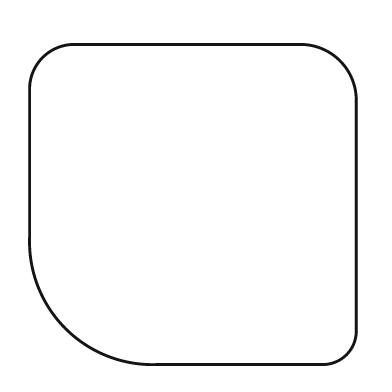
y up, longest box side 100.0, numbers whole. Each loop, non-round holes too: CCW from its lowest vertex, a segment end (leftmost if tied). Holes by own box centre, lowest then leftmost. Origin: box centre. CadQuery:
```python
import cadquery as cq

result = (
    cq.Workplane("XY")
    .moveTo(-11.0, -49.0)
    .lineTo(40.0, -49.0)
    .threePointArc((47.0, -46.0), (50.0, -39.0))
    .lineTo(50.0, 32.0)
    .threePointArc((45.0, 44.0), (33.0, 49.0))
    .lineTo(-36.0, 49.0)
    .threePointArc((-46.0, 45.0), (-50.0, 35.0))
    .lineTo(-50.0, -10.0)
    .threePointArc((-39.0, -38.0), (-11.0, -49.0))
    .close()
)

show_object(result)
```